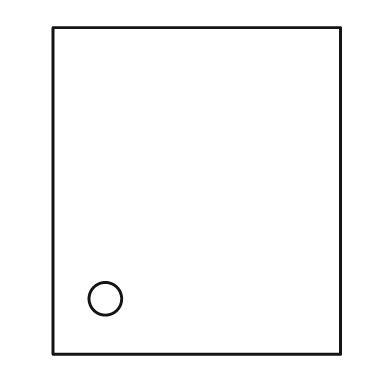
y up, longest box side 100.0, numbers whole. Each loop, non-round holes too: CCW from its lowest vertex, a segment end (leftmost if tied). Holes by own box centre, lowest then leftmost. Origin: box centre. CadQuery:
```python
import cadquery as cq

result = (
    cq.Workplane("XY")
    .moveTo(-44.0, -50.0)
    .lineTo(44.0, -50.0)
    .lineTo(44.0, 50.0)
    .lineTo(-44.0, 50.0)
    .close()
    .moveTo(-28.0, -33.0)
    .circle(5.0)
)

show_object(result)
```